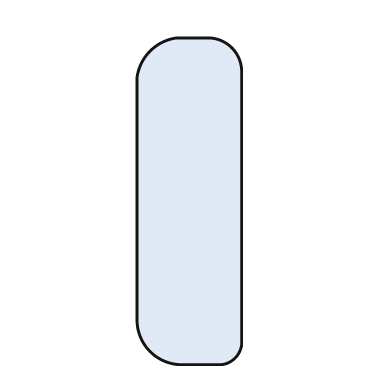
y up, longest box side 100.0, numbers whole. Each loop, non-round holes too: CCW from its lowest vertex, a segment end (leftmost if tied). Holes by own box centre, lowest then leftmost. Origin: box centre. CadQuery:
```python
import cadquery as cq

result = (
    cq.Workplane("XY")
    .moveTo(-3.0, -50.0)
    .lineTo(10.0, -50.0)
    .threePointArc((14.0, -48.0), (16.0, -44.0))
    .lineTo(16.0, 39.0)
    .threePointArc((13.0, 47.0), (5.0, 50.0))
    .lineTo(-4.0, 50.0)
    .threePointArc((-12.0, 46.0), (-16.0, 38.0))
    .lineTo(-16.0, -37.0)
    .threePointArc((-12.0, -46.0), (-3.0, -50.0))
    .close()
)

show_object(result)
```